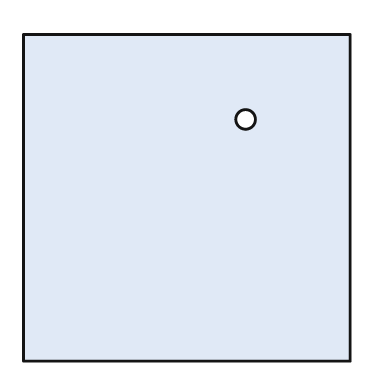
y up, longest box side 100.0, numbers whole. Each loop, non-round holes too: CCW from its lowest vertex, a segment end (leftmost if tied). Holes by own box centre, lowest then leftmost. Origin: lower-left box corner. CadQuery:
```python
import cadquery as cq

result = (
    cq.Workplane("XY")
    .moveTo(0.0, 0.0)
    .lineTo(100.0, 0.0)
    .lineTo(100.0, 100.0)
    .lineTo(0.0, 100.0)
    .close()
    .moveTo(68.0, 74.0)
    .circle(3.0)
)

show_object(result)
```